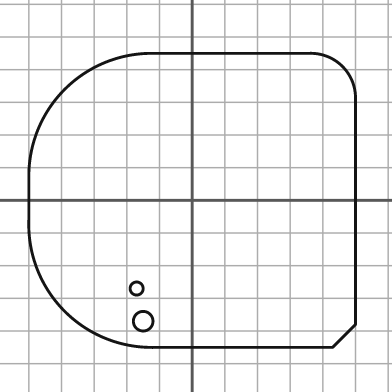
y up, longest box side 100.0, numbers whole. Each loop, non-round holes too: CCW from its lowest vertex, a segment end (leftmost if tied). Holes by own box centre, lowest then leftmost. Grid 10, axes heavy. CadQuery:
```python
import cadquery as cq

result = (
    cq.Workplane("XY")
    .moveTo(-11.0, -45.0)
    .lineTo(43.0, -45.0)
    .lineTo(50.0, -38.0)
    .lineTo(50.0, 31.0)
    .threePointArc((46.0, 41.0), (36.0, 45.0))
    .lineTo(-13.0, 45.0)
    .threePointArc((-39.0, 34.0), (-50.0, 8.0))
    .lineTo(-50.0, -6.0)
    .threePointArc((-39.0, -34.0), (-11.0, -45.0))
    .close()
    .moveTo(-15.0, -37.0)
    .circle(3.0)
    .moveTo(-17.0, -27.0)
    .circle(2.0)
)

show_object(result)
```